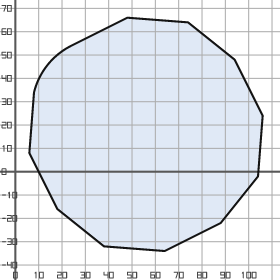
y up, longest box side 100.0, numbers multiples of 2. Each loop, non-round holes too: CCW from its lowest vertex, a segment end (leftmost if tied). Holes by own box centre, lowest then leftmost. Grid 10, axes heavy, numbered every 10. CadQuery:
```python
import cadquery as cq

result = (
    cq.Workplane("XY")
    .moveTo(64.0, -34.0)
    .lineTo(88.0, -22.0)
    .lineTo(104.0, -2.0)
    .lineTo(106.0, 24.0)
    .lineTo(94.0, 48.0)
    .lineTo(74.0, 64.0)
    .lineTo(48.0, 66.0)
    .lineTo(24.0, 54.0)
    .threePointArc((14.0, 46.0), (8.0, 34.0))
    .lineTo(6.0, 8.0)
    .lineTo(18.0, -16.0)
    .lineTo(38.0, -32.0)
    .close()
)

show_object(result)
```